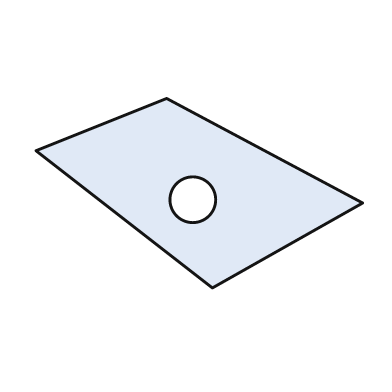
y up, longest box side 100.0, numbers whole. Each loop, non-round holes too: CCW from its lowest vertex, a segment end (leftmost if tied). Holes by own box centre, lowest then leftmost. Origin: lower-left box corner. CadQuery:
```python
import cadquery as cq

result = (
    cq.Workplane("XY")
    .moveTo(54.0, 0.0)
    .lineTo(100.0, 26.0)
    .lineTo(40.0, 58.0)
    .lineTo(0.0, 42.0)
    .close()
    .moveTo(48.0, 27.0)
    .circle(7.0)
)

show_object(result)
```